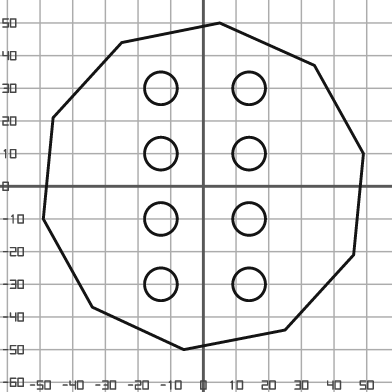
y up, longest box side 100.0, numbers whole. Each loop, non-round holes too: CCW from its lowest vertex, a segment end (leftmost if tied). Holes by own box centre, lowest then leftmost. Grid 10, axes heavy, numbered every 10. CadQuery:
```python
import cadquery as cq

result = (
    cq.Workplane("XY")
    .moveTo(-6.0, -50.0)
    .lineTo(25.0, -44.0)
    .lineTo(46.0, -21.0)
    .lineTo(49.0, 10.0)
    .lineTo(34.0, 37.0)
    .lineTo(5.0, 50.0)
    .lineTo(-25.0, 44.0)
    .lineTo(-46.0, 21.0)
    .lineTo(-49.0, -10.0)
    .lineTo(-34.0, -37.0)
    .close()
    .moveTo(-13.0, -30.0)
    .circle(5.0)
    .moveTo(14.0, -30.0)
    .circle(5.0)
    .moveTo(-13.0, -10.0)
    .circle(5.0)
    .moveTo(14.0, -10.0)
    .circle(5.0)
    .moveTo(-13.0, 10.0)
    .circle(5.0)
    .moveTo(14.0, 10.0)
    .circle(5.0)
    .moveTo(-13.0, 30.0)
    .circle(5.0)
    .moveTo(14.0, 30.0)
    .circle(5.0)
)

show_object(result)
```